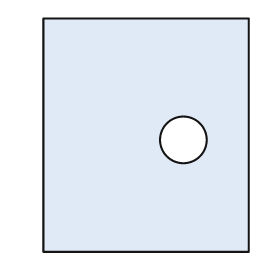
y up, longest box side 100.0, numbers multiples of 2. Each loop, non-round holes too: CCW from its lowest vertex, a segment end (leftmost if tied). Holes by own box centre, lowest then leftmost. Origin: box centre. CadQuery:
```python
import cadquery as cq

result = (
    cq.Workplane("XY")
    .moveTo(-44.0, -50.0)
    .lineTo(44.0, -50.0)
    .lineTo(44.0, 50.0)
    .lineTo(-44.0, 50.0)
    .close()
    .moveTo(16.0, -2.0)
    .circle(10.0)
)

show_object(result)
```